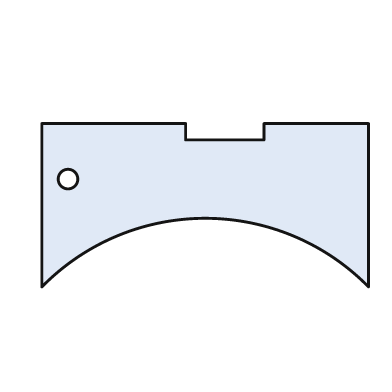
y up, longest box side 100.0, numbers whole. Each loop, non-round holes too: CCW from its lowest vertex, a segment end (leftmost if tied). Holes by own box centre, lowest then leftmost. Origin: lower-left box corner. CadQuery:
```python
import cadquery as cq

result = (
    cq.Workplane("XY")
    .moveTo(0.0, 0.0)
    .threePointArc((50.0, 21.0), (100.0, 0.0))
    .lineTo(100.0, 50.0)
    .lineTo(68.0, 50.0)
    .lineTo(68.0, 45.0)
    .lineTo(44.0, 45.0)
    .lineTo(44.0, 50.0)
    .lineTo(0.0, 50.0)
    .close()
    .moveTo(8.0, 33.0)
    .circle(3.0)
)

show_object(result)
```